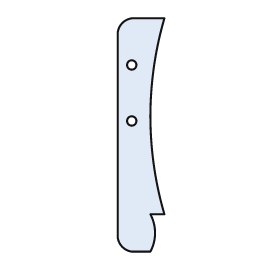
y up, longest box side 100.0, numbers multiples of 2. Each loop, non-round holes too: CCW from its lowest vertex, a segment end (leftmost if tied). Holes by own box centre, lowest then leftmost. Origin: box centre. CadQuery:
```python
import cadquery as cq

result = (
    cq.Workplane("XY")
    .moveTo(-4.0, -50.0)
    .lineTo(4.0, -50.0)
    .threePointArc((6.0, -42.0), (4.0, -34.0))
    .lineTo(10.0, -34.0)
    .threePointArc((4.0, 8.0), (10.0, 50.0))
    .lineTo(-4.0, 50.0)
    .threePointArc((-8.0, 48.0), (-10.0, 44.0))
    .lineTo(-10.0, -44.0)
    .threePointArc((-8.0, -48.0), (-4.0, -50.0))
    .close()
    .moveTo(-4.0, 6.0)
    .circle(2.0)
    .moveTo(-4.0, 30.0)
    .circle(2.0)
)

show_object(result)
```